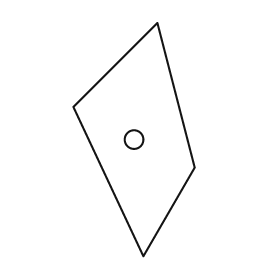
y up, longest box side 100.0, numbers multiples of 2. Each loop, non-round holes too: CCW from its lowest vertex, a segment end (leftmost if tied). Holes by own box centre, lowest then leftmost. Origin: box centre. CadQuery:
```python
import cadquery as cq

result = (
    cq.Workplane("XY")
    .moveTo(4.0, -50.0)
    .lineTo(26.0, -12.0)
    .lineTo(10.0, 50.0)
    .lineTo(-26.0, 14.0)
    .close()
    .moveTo(0.0, 0.0)
    .circle(4.0)
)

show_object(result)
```